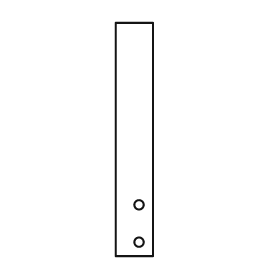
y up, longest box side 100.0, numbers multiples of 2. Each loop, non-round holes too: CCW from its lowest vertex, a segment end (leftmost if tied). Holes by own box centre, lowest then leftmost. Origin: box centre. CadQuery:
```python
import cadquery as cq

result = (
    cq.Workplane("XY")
    .moveTo(-8.0, -50.0)
    .lineTo(8.0, -50.0)
    .lineTo(8.0, 50.0)
    .lineTo(-8.0, 50.0)
    .close()
    .moveTo(2.0, -44.0)
    .circle(2.0)
    .moveTo(2.0, -28.0)
    .circle(2.0)
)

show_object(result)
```